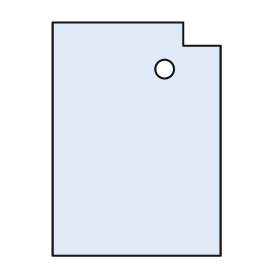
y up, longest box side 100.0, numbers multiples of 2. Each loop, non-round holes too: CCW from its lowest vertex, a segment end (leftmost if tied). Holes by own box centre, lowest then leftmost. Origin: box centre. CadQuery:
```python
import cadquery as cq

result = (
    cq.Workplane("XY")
    .moveTo(-36.0, -50.0)
    .lineTo(36.0, -50.0)
    .lineTo(36.0, 40.0)
    .lineTo(20.0, 40.0)
    .lineTo(20.0, 50.0)
    .lineTo(-36.0, 50.0)
    .close()
    .moveTo(12.0, 30.0)
    .circle(4.0)
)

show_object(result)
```